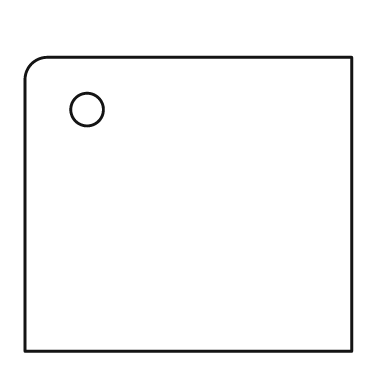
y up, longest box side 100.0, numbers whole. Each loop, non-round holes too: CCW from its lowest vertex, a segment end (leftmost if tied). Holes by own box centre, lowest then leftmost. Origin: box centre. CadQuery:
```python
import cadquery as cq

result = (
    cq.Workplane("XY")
    .moveTo(-50.0, -45.0)
    .lineTo(50.0, -45.0)
    .lineTo(50.0, 45.0)
    .lineTo(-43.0, 45.0)
    .threePointArc((-48.0, 43.0), (-50.0, 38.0))
    .close()
    .moveTo(-31.0, 29.0)
    .circle(5.0)
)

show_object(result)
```